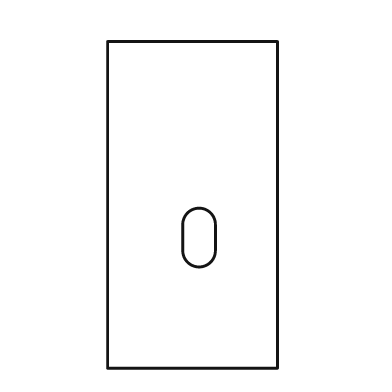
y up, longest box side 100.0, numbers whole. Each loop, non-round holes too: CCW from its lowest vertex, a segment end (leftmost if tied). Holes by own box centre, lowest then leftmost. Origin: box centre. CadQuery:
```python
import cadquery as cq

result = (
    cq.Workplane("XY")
    .moveTo(-26.0, -50.0)
    .lineTo(26.0, -50.0)
    .lineTo(26.0, 50.0)
    .lineTo(-26.0, 50.0)
    .close()
    .moveTo(-3.0, -14.0)
    .threePointArc((2.0, -19.0), (7.0, -14.0))
    .lineTo(7.0, -6.0)
    .threePointArc((2.0, -1.0), (-3.0, -6.0))
    .close()
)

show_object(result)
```